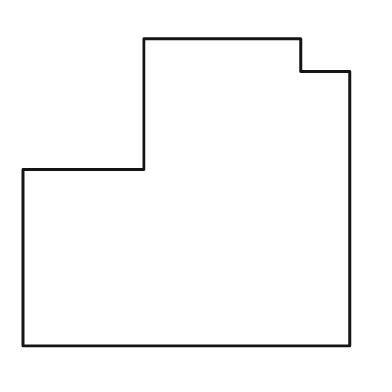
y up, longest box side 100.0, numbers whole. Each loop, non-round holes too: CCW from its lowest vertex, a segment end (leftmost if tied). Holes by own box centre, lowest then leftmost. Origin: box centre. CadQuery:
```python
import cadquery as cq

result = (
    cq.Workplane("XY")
    .moveTo(-50.0, -47.0)
    .lineTo(50.0, -47.0)
    .lineTo(50.0, 37.0)
    .lineTo(35.0, 37.0)
    .lineTo(35.0, 47.0)
    .lineTo(-13.0, 47.0)
    .lineTo(-13.0, 7.0)
    .lineTo(-50.0, 7.0)
    .close()
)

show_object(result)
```